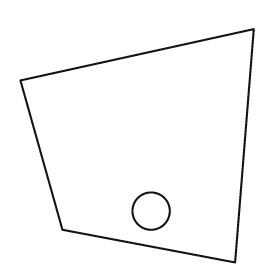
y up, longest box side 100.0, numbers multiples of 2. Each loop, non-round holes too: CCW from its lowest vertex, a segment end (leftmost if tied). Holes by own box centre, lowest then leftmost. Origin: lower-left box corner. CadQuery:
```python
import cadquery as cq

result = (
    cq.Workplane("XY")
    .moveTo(92.0, 0.0)
    .lineTo(100.0, 100.0)
    .lineTo(0.0, 78.0)
    .lineTo(18.0, 14.0)
    .close()
    .moveTo(56.0, 22.0)
    .circle(8.0)
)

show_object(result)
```